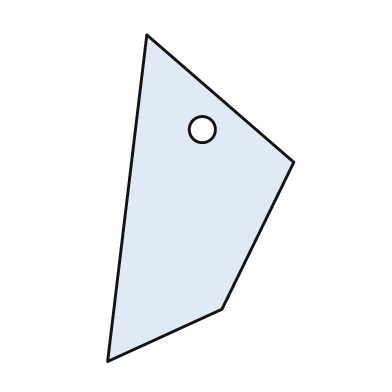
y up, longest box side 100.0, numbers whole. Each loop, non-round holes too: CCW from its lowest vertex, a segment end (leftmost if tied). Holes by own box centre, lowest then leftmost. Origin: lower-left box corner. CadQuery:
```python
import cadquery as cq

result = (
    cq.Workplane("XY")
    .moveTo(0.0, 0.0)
    .lineTo(35.0, 16.0)
    .lineTo(57.0, 61.0)
    .lineTo(12.0, 100.0)
    .close()
    .moveTo(29.0, 71.0)
    .circle(4.0)
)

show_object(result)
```